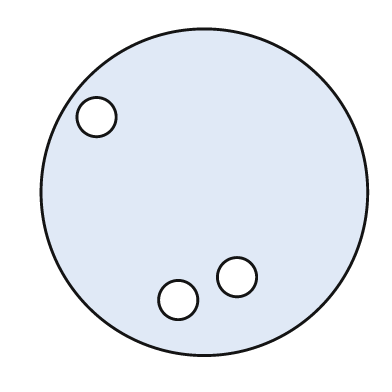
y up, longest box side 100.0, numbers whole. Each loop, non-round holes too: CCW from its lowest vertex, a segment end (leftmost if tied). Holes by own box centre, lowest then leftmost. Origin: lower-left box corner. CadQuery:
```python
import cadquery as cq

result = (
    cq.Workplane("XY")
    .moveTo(50.0, 50.0)
    .circle(50.0)
    .moveTo(42.0, 17.0)
    .circle(6.0)
    .moveTo(60.0, 24.0)
    .circle(6.0)
    .moveTo(17.0, 73.0)
    .circle(6.0)
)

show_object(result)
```